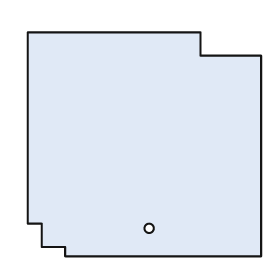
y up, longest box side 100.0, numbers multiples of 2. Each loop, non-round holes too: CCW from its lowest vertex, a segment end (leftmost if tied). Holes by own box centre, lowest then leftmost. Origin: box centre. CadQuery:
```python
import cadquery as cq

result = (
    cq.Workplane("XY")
    .moveTo(-34.0, -48.0)
    .lineTo(50.0, -48.0)
    .lineTo(50.0, 38.0)
    .lineTo(24.0, 38.0)
    .lineTo(24.0, 48.0)
    .lineTo(-50.0, 48.0)
    .lineTo(-50.0, -34.0)
    .lineTo(-44.0, -34.0)
    .lineTo(-44.0, -44.0)
    .lineTo(-34.0, -44.0)
    .close()
    .moveTo(2.0, -36.0)
    .circle(2.0)
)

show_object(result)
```